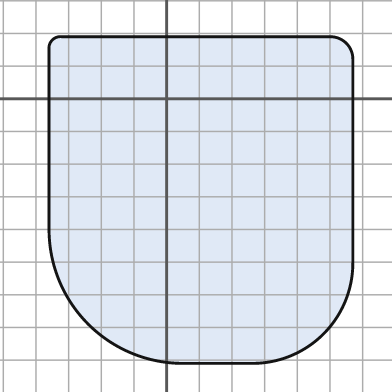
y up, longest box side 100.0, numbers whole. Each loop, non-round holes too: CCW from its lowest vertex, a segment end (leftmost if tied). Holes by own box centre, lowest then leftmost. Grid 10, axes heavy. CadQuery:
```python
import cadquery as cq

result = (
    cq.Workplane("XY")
    .moveTo(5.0, -81.0)
    .lineTo(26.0, -81.0)
    .threePointArc((48.0, -72.0), (57.0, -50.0))
    .lineTo(57.0, 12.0)
    .threePointArc((55.0, 17.0), (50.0, 19.0))
    .lineTo(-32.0, 19.0)
    .threePointArc((-35.0, 18.0), (-36.0, 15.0))
    .lineTo(-36.0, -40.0)
    .threePointArc((-24.0, -69.0), (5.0, -81.0))
    .close()
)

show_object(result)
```